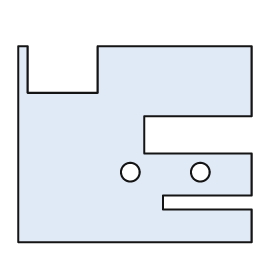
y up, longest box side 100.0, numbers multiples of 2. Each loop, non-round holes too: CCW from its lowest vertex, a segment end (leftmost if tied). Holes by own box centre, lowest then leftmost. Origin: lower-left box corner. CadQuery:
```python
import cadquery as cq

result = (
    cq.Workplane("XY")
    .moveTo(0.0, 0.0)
    .lineTo(100.0, 0.0)
    .lineTo(100.0, 14.0)
    .lineTo(62.0, 14.0)
    .lineTo(62.0, 20.0)
    .lineTo(100.0, 20.0)
    .lineTo(100.0, 38.0)
    .lineTo(54.0, 38.0)
    .lineTo(54.0, 54.0)
    .lineTo(100.0, 54.0)
    .lineTo(100.0, 84.0)
    .lineTo(34.0, 84.0)
    .lineTo(34.0, 64.0)
    .lineTo(4.0, 64.0)
    .lineTo(4.0, 84.0)
    .lineTo(0.0, 84.0)
    .close()
    .moveTo(48.0, 30.0)
    .circle(4.0)
    .moveTo(78.0, 30.0)
    .circle(4.0)
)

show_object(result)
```